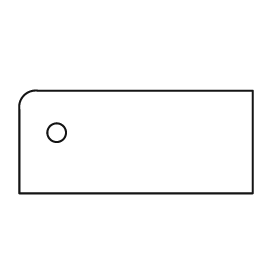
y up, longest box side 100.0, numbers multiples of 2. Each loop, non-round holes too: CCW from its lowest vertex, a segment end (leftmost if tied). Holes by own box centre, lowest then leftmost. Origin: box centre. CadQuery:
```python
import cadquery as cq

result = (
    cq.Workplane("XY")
    .moveTo(-50.0, -22.0)
    .lineTo(50.0, -22.0)
    .lineTo(50.0, 22.0)
    .lineTo(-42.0, 22.0)
    .threePointArc((-48.0, 20.0), (-50.0, 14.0))
    .close()
    .moveTo(-34.0, 4.0)
    .circle(4.0)
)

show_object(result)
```